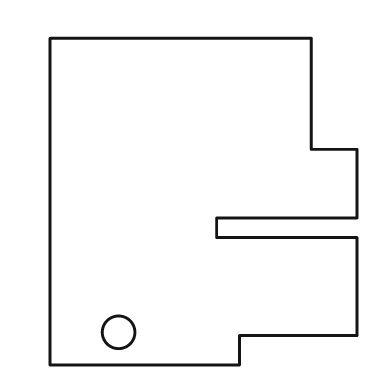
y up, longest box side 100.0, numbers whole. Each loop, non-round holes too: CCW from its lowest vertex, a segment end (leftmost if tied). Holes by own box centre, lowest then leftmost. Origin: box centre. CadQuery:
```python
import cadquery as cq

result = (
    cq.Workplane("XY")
    .moveTo(-47.0, -50.0)
    .lineTo(11.0, -50.0)
    .lineTo(11.0, -41.0)
    .lineTo(47.0, -41.0)
    .lineTo(47.0, -11.0)
    .lineTo(4.0, -11.0)
    .lineTo(4.0, -5.0)
    .lineTo(47.0, -5.0)
    .lineTo(47.0, 16.0)
    .lineTo(33.0, 16.0)
    .lineTo(33.0, 50.0)
    .lineTo(-47.0, 50.0)
    .close()
    .moveTo(-26.0, -40.0)
    .circle(5.0)
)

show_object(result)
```